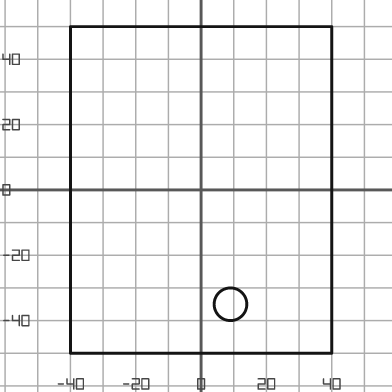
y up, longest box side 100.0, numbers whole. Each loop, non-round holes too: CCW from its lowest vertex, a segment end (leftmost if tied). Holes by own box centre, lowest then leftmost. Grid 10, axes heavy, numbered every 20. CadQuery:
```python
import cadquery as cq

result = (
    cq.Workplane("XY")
    .moveTo(-40.0, -50.0)
    .lineTo(40.0, -50.0)
    .lineTo(40.0, 50.0)
    .lineTo(-40.0, 50.0)
    .close()
    .moveTo(9.0, -35.0)
    .circle(5.0)
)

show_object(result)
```